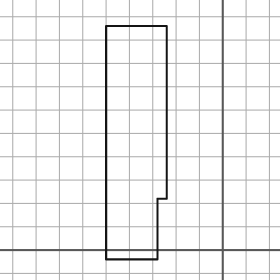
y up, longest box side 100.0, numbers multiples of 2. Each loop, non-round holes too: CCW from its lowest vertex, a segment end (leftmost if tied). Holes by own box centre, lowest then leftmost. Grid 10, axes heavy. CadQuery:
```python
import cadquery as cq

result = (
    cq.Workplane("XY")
    .moveTo(-50.0, -4.0)
    .lineTo(-28.0, -4.0)
    .lineTo(-28.0, 22.0)
    .lineTo(-24.0, 22.0)
    .lineTo(-24.0, 96.0)
    .lineTo(-50.0, 96.0)
    .close()
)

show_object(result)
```